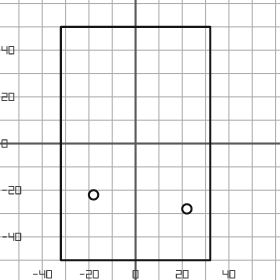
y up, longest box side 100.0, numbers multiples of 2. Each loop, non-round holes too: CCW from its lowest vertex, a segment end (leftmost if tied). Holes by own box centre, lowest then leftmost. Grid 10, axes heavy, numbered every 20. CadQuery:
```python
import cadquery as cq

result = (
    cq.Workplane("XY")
    .moveTo(-32.0, -50.0)
    .lineTo(32.0, -50.0)
    .lineTo(32.0, 50.0)
    .lineTo(-32.0, 50.0)
    .close()
    .moveTo(22.0, -28.0)
    .circle(2.0)
    .moveTo(-18.0, -22.0)
    .circle(2.0)
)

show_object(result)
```